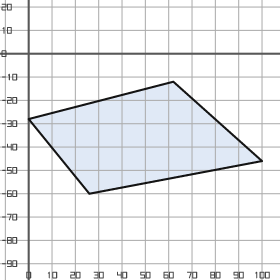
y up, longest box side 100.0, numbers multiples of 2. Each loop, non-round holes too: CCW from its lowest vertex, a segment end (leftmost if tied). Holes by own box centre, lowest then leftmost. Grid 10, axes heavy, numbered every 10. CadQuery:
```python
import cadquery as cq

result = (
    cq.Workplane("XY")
    .moveTo(26.0, -60.0)
    .lineTo(100.0, -46.0)
    .lineTo(62.0, -12.0)
    .lineTo(0.0, -28.0)
    .close()
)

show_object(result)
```